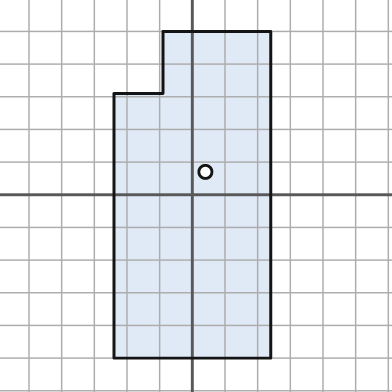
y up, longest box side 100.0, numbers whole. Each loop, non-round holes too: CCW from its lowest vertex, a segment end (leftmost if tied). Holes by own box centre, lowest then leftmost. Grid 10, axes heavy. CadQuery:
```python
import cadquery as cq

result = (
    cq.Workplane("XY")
    .moveTo(-24.0, -50.0)
    .lineTo(24.0, -50.0)
    .lineTo(24.0, 50.0)
    .lineTo(-9.0, 50.0)
    .lineTo(-9.0, 31.0)
    .lineTo(-24.0, 31.0)
    .close()
    .moveTo(4.0, 7.0)
    .circle(2.0)
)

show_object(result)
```